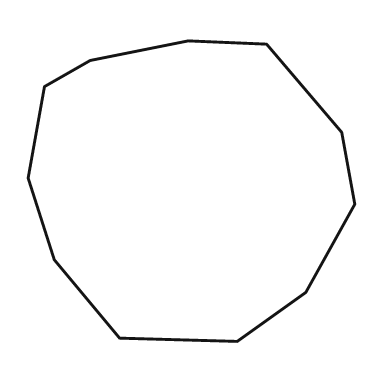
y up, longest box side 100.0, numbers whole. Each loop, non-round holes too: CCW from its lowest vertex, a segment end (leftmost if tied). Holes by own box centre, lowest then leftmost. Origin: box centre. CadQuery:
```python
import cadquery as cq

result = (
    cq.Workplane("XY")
    .moveTo(14.0, -46.0)
    .lineTo(35.0, -31.0)
    .lineTo(50.0, -4.0)
    .lineTo(46.0, 18.0)
    .lineTo(23.0, 45.0)
    .lineTo(-1.0, 46.0)
    .lineTo(-31.0, 40.0)
    .lineTo(-45.0, 32.0)
    .lineTo(-50.0, 4.0)
    .lineTo(-42.0, -21.0)
    .lineTo(-22.0, -45.0)
    .close()
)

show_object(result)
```